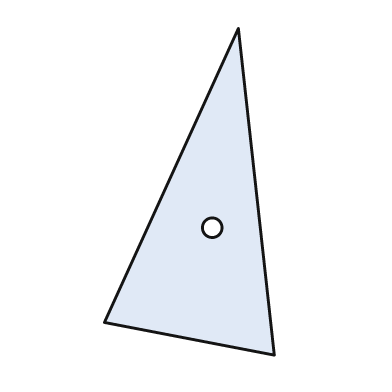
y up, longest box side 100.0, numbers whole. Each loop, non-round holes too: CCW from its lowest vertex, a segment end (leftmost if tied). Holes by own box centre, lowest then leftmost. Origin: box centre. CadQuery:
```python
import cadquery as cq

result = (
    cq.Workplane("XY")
    .moveTo(26.0, -50.0)
    .lineTo(15.0, 50.0)
    .lineTo(-26.0, -40.0)
    .close()
    .moveTo(7.0, -11.0)
    .circle(3.0)
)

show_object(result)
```